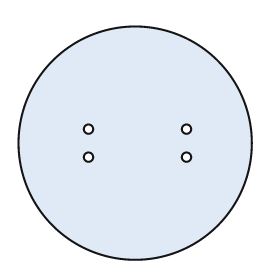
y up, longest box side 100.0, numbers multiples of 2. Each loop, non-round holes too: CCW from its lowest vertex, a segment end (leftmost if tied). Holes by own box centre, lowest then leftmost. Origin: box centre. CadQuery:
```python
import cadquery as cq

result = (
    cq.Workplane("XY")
    .moveTo(0.0, 0.0)
    .circle(50.0)
    .moveTo(-20.0, -6.0)
    .circle(2.0)
    .moveTo(22.0, -6.0)
    .circle(2.0)
    .moveTo(-20.0, 6.0)
    .circle(2.0)
    .moveTo(22.0, 6.0)
    .circle(2.0)
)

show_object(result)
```